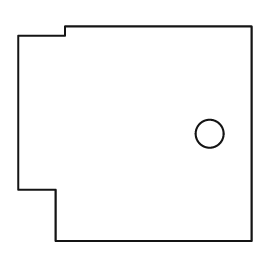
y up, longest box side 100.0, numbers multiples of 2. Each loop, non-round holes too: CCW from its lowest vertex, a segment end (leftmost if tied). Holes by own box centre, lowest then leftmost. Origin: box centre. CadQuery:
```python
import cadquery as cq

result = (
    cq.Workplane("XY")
    .moveTo(-34.0, -46.0)
    .lineTo(50.0, -46.0)
    .lineTo(50.0, 46.0)
    .lineTo(-30.0, 46.0)
    .lineTo(-30.0, 42.0)
    .lineTo(-50.0, 42.0)
    .lineTo(-50.0, -24.0)
    .lineTo(-34.0, -24.0)
    .close()
    .moveTo(32.0, 0.0)
    .circle(6.0)
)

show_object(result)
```